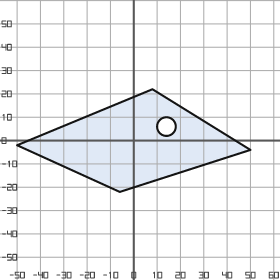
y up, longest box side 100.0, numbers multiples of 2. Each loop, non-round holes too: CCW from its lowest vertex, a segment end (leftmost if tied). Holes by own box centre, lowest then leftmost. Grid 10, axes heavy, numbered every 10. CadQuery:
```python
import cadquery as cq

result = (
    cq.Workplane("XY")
    .moveTo(-6.0, -22.0)
    .lineTo(50.0, -4.0)
    .lineTo(8.0, 22.0)
    .lineTo(-50.0, -2.0)
    .close()
    .moveTo(14.0, 6.0)
    .circle(4.0)
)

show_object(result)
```